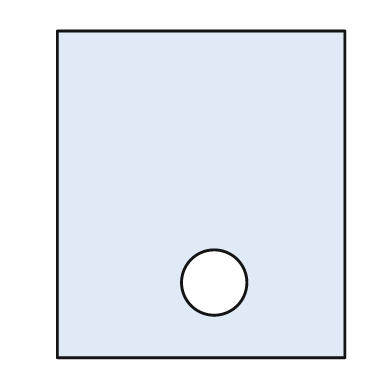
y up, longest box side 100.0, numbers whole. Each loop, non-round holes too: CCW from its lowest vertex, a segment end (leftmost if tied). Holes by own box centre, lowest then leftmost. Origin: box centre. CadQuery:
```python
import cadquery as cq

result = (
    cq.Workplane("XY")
    .moveTo(-44.0, -50.0)
    .lineTo(44.0, -50.0)
    .lineTo(44.0, 50.0)
    .lineTo(-44.0, 50.0)
    .close()
    .moveTo(4.0, -27.0)
    .circle(10.0)
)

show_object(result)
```